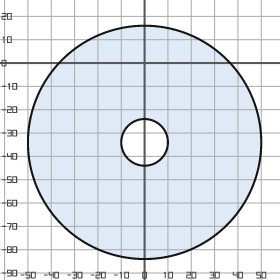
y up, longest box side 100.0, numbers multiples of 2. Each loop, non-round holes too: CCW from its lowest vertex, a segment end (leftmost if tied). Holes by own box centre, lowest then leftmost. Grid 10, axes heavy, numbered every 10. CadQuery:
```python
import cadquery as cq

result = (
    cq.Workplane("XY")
    .moveTo(0.0, -34.0)
    .circle(50.0)
    .moveTo(0.0, -34.0)
    .circle(10.0)
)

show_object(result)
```